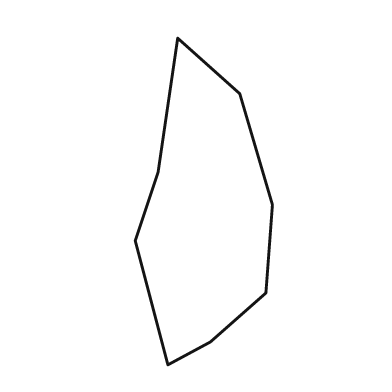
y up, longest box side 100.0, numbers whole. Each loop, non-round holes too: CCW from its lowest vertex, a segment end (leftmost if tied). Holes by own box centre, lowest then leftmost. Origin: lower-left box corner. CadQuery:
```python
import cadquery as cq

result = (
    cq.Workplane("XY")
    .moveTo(10.0, 0.0)
    .lineTo(23.0, 7.0)
    .lineTo(40.0, 22.0)
    .lineTo(42.0, 49.0)
    .lineTo(32.0, 83.0)
    .lineTo(13.0, 100.0)
    .lineTo(7.0, 59.0)
    .lineTo(0.0, 38.0)
    .close()
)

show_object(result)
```